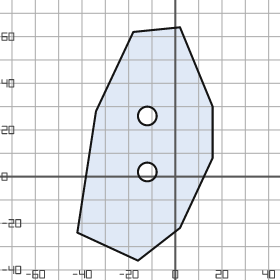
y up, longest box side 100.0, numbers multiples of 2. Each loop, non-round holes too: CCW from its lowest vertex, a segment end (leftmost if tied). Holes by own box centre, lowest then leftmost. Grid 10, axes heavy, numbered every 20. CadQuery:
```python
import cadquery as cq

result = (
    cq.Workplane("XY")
    .moveTo(-16.0, -36.0)
    .lineTo(2.0, -22.0)
    .lineTo(16.0, 8.0)
    .lineTo(16.0, 30.0)
    .lineTo(2.0, 64.0)
    .lineTo(-18.0, 62.0)
    .lineTo(-34.0, 28.0)
    .lineTo(-42.0, -24.0)
    .close()
    .moveTo(-12.0, 2.0)
    .circle(4.0)
    .moveTo(-12.0, 26.0)
    .circle(4.0)
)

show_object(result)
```